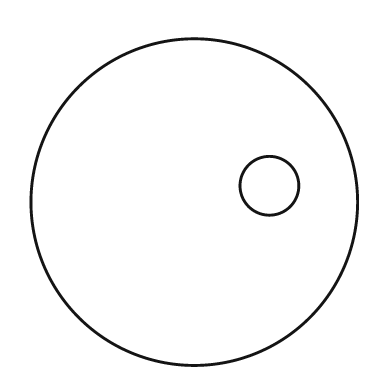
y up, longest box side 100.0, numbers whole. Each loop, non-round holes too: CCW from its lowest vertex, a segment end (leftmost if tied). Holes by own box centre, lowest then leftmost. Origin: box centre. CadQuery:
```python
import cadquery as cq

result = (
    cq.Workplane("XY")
    .moveTo(0.0, 0.0)
    .circle(50.0)
    .moveTo(23.0, 5.0)
    .circle(9.0)
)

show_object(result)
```